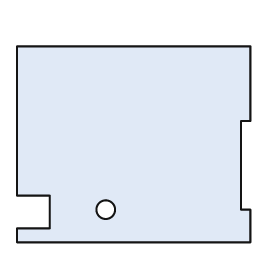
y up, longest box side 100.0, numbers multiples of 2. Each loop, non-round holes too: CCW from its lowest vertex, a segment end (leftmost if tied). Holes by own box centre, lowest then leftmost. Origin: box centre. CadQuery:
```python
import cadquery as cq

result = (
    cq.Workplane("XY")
    .moveTo(-50.0, -42.0)
    .lineTo(50.0, -42.0)
    .lineTo(50.0, -28.0)
    .lineTo(46.0, -28.0)
    .lineTo(46.0, 10.0)
    .lineTo(50.0, 10.0)
    .lineTo(50.0, 42.0)
    .lineTo(-50.0, 42.0)
    .lineTo(-50.0, -22.0)
    .lineTo(-36.0, -22.0)
    .lineTo(-36.0, -36.0)
    .lineTo(-50.0, -36.0)
    .close()
    .moveTo(-12.0, -28.0)
    .circle(4.0)
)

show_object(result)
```